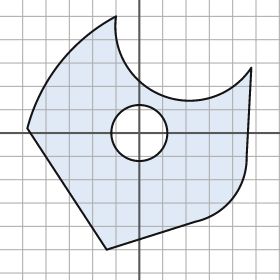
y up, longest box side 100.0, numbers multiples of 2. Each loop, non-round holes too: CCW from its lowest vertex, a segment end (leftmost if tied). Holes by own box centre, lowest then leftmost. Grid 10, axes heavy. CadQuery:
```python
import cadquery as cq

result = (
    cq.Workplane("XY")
    .moveTo(-14.0, -50.0)
    .lineTo(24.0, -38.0)
    .threePointArc((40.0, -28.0), (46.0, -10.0))
    .lineTo(48.0, 28.0)
    .threePointArc((10.0, 16.0), (-10.0, 50.0))
    .threePointArc((-34.0, 30.0), (-48.0, 2.0))
    .close()
    .moveTo(0.0, 0.0)
    .circle(12.0)
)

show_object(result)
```